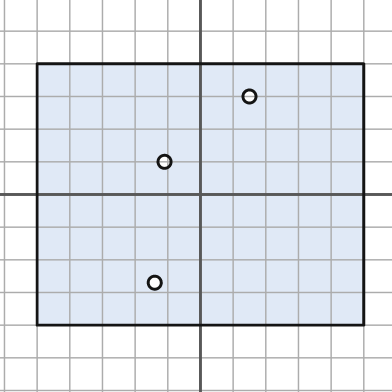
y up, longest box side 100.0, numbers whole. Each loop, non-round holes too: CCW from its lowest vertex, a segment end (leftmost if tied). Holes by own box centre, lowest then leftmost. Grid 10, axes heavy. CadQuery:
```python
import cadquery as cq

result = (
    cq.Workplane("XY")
    .moveTo(-50.0, -40.0)
    .lineTo(50.0, -40.0)
    .lineTo(50.0, 40.0)
    .lineTo(-50.0, 40.0)
    .close()
    .moveTo(-14.0, -27.0)
    .circle(2.0)
    .moveTo(-11.0, 10.0)
    .circle(2.0)
    .moveTo(15.0, 30.0)
    .circle(2.0)
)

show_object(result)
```